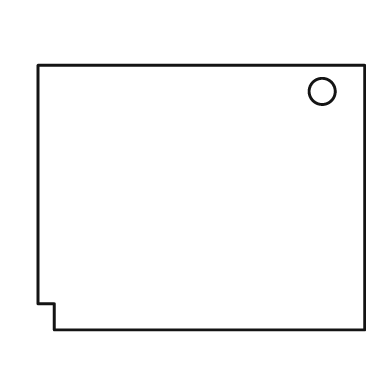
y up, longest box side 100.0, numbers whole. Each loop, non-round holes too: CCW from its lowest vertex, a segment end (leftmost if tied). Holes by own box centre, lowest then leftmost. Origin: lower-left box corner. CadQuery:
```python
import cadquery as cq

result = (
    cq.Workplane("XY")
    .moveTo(5.0, 0.0)
    .lineTo(100.0, 0.0)
    .lineTo(100.0, 81.0)
    .lineTo(0.0, 81.0)
    .lineTo(0.0, 8.0)
    .lineTo(5.0, 8.0)
    .close()
    .moveTo(87.0, 73.0)
    .circle(4.0)
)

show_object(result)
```